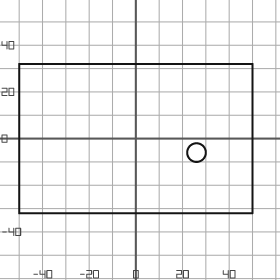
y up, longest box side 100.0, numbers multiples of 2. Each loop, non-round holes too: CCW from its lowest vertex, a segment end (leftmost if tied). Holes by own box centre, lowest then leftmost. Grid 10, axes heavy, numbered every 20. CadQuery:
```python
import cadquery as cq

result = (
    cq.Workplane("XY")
    .moveTo(-50.0, -32.0)
    .lineTo(50.0, -32.0)
    .lineTo(50.0, 32.0)
    .lineTo(-50.0, 32.0)
    .close()
    .moveTo(26.0, -6.0)
    .circle(4.0)
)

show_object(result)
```